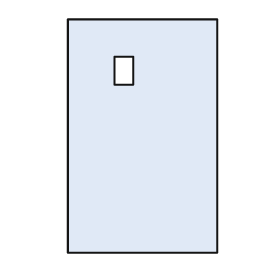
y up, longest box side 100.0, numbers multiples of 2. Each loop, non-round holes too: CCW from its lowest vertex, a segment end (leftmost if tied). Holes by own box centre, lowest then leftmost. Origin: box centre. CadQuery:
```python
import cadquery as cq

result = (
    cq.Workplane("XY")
    .moveTo(-32.0, -50.0)
    .lineTo(32.0, -50.0)
    .lineTo(32.0, 50.0)
    .lineTo(-32.0, 50.0)
    .close()
    .moveTo(-12.0, 22.0)
    .lineTo(-4.0, 22.0)
    .lineTo(-4.0, 34.0)
    .lineTo(-12.0, 34.0)
    .close()
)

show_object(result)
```